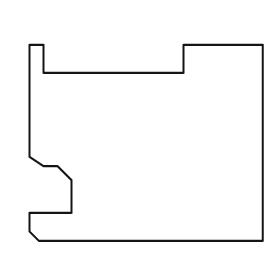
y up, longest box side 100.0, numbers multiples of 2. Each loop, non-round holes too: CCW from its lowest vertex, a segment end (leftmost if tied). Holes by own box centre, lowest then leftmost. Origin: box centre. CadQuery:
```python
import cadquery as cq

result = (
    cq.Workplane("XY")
    .moveTo(-46.0, -42.0)
    .lineTo(50.0, -42.0)
    .lineTo(50.0, 42.0)
    .lineTo(16.0, 42.0)
    .lineTo(16.0, 30.0)
    .lineTo(-44.0, 30.0)
    .lineTo(-44.0, 42.0)
    .lineTo(-50.0, 42.0)
    .lineTo(-50.0, -6.0)
    .lineTo(-44.0, -10.0)
    .lineTo(-38.0, -10.0)
    .lineTo(-32.0, -16.0)
    .lineTo(-32.0, -30.0)
    .lineTo(-50.0, -30.0)
    .lineTo(-50.0, -38.0)
    .close()
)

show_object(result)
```